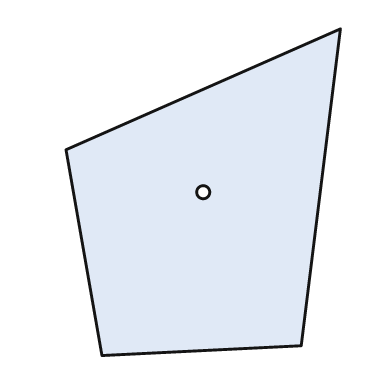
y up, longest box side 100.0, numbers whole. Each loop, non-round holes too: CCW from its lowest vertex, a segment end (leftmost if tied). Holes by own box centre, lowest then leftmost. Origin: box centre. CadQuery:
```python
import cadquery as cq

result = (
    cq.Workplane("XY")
    .moveTo(-31.0, -50.0)
    .lineTo(30.0, -47.0)
    .lineTo(42.0, 50.0)
    .lineTo(-42.0, 13.0)
    .close()
    .moveTo(0.0, 0.0)
    .circle(2.0)
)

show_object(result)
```